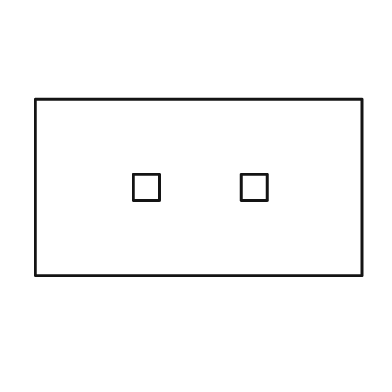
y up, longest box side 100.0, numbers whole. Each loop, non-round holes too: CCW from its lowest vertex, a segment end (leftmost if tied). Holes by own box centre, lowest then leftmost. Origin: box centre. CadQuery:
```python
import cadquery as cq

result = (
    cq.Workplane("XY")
    .moveTo(-50.0, -27.0)
    .lineTo(50.0, -27.0)
    .lineTo(50.0, 27.0)
    .lineTo(-50.0, 27.0)
    .close()
    .moveTo(-20.0, -4.0)
    .lineTo(-12.0, -4.0)
    .lineTo(-12.0, 4.0)
    .lineTo(-20.0, 4.0)
    .close()
    .moveTo(13.0, -4.0)
    .lineTo(21.0, -4.0)
    .lineTo(21.0, 4.0)
    .lineTo(13.0, 4.0)
    .close()
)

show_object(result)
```